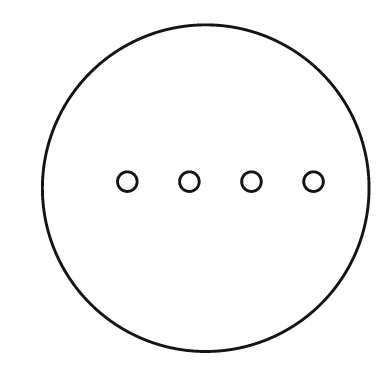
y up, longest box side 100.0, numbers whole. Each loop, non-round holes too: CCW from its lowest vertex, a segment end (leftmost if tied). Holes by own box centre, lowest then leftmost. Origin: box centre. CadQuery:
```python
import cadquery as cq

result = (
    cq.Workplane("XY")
    .moveTo(0.0, 0.0)
    .circle(50.0)
    .moveTo(-24.0, 2.0)
    .circle(3.0)
    .moveTo(-5.0, 2.0)
    .circle(3.0)
    .moveTo(14.0, 2.0)
    .circle(3.0)
    .moveTo(33.0, 2.0)
    .circle(3.0)
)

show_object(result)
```